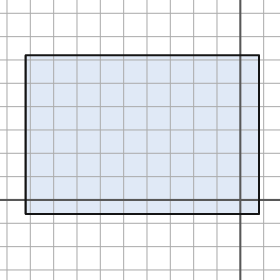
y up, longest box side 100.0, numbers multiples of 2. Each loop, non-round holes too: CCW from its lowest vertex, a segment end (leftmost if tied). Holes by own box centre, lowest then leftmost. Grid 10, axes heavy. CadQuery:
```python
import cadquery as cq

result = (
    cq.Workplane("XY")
    .moveTo(-92.0, -6.0)
    .lineTo(8.0, -6.0)
    .lineTo(8.0, 62.0)
    .lineTo(-92.0, 62.0)
    .close()
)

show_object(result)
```